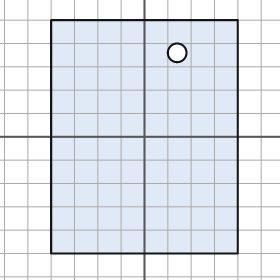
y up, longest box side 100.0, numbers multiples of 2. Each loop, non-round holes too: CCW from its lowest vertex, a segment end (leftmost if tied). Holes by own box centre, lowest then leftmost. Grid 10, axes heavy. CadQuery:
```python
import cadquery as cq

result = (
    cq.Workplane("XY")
    .moveTo(-40.0, -50.0)
    .lineTo(40.0, -50.0)
    .lineTo(40.0, 50.0)
    .lineTo(-40.0, 50.0)
    .close()
    .moveTo(14.0, 36.0)
    .circle(4.0)
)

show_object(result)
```